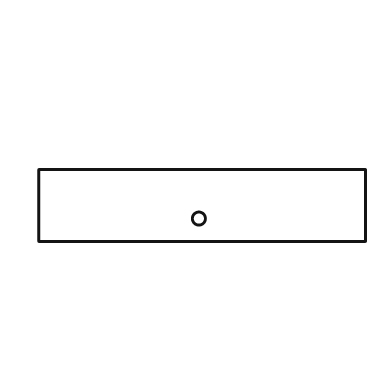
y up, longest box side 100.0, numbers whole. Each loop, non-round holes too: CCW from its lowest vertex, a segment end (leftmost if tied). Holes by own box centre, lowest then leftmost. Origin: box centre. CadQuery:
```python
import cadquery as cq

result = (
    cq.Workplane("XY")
    .moveTo(-50.0, -11.0)
    .lineTo(50.0, -11.0)
    .lineTo(50.0, 11.0)
    .lineTo(-50.0, 11.0)
    .close()
    .moveTo(-1.0, -4.0)
    .circle(2.0)
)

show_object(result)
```